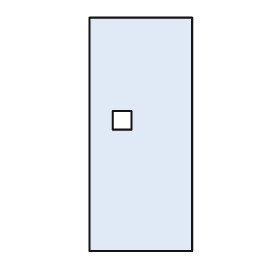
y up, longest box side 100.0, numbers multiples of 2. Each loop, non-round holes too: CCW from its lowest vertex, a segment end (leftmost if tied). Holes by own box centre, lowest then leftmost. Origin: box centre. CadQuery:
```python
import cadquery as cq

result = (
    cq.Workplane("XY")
    .moveTo(-22.0, -50.0)
    .lineTo(22.0, -50.0)
    .lineTo(22.0, 50.0)
    .lineTo(-22.0, 50.0)
    .close()
    .moveTo(-12.0, 2.0)
    .lineTo(-4.0, 2.0)
    .lineTo(-4.0, 10.0)
    .lineTo(-12.0, 10.0)
    .close()
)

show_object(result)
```